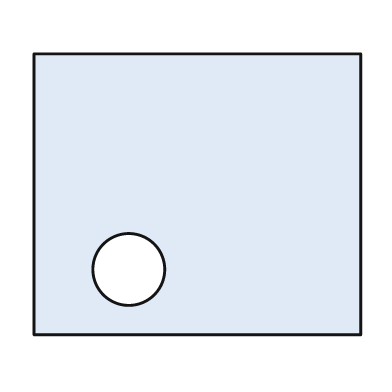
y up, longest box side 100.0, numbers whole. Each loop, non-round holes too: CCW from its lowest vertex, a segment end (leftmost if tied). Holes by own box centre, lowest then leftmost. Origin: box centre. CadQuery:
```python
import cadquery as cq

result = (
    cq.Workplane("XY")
    .moveTo(-50.0, -43.0)
    .lineTo(50.0, -43.0)
    .lineTo(50.0, 43.0)
    .lineTo(-50.0, 43.0)
    .close()
    .moveTo(-21.0, -23.0)
    .circle(11.0)
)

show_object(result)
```